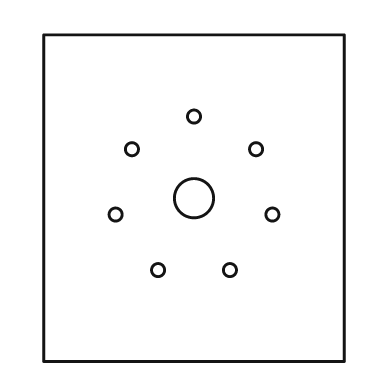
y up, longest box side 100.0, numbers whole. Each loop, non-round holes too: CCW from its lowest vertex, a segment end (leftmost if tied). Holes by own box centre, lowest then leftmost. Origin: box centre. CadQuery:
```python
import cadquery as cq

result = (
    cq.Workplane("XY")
    .moveTo(-46.0, -50.0)
    .lineTo(46.0, -50.0)
    .lineTo(46.0, 50.0)
    .lineTo(-46.0, 50.0)
    .close()
    .moveTo(-11.0, -22.0)
    .circle(2.0)
    .moveTo(11.0, -22.0)
    .circle(2.0)
    .moveTo(-24.0, -5.0)
    .circle(2.0)
    .moveTo(24.0, -5.0)
    .circle(2.0)
    .moveTo(0.0, 0.0)
    .circle(6.0)
    .moveTo(-19.0, 15.0)
    .circle(2.0)
    .moveTo(19.0, 15.0)
    .circle(2.0)
    .moveTo(0.0, 25.0)
    .circle(2.0)
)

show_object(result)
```